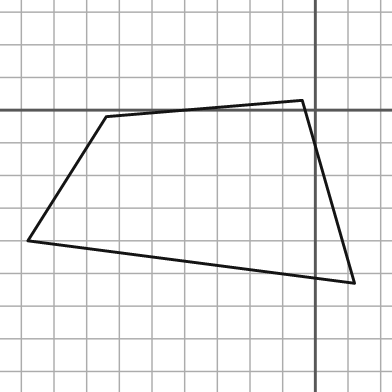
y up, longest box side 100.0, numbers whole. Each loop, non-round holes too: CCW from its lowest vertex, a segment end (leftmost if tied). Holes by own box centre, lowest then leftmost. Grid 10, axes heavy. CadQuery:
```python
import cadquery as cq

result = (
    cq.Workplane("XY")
    .moveTo(12.0, -53.0)
    .lineTo(-4.0, 3.0)
    .lineTo(-64.0, -2.0)
    .lineTo(-88.0, -40.0)
    .close()
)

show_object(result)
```